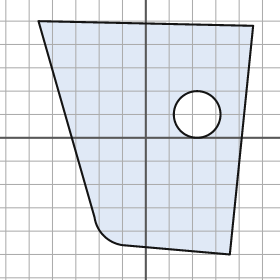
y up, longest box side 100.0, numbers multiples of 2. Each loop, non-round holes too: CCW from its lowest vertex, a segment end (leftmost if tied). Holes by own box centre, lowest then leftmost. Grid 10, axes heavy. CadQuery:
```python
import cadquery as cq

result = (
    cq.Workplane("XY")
    .moveTo(36.0, -50.0)
    .lineTo(46.0, 48.0)
    .lineTo(-46.0, 50.0)
    .lineTo(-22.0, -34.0)
    .threePointArc((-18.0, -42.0), (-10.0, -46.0))
    .close()
    .moveTo(22.0, 10.0)
    .circle(10.0)
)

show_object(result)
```